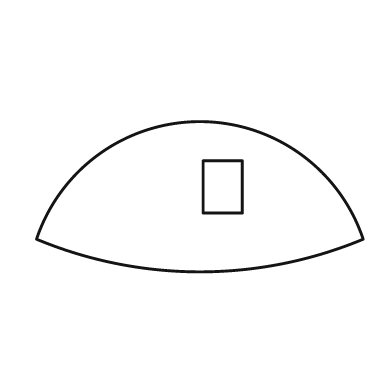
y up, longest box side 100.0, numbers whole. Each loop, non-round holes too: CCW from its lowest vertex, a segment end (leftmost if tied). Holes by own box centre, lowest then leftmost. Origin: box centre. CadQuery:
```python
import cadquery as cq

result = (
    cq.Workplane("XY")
    .moveTo(-50.0, -13.0)
    .threePointArc((0.0, -23.0), (50.0, -13.0))
    .threePointArc((0.0, 23.0), (-50.0, -13.0))
    .close()
    .moveTo(1.0, -5.0)
    .lineTo(13.0, -5.0)
    .lineTo(13.0, 11.0)
    .lineTo(1.0, 11.0)
    .close()
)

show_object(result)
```